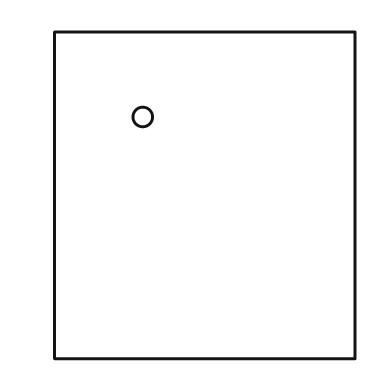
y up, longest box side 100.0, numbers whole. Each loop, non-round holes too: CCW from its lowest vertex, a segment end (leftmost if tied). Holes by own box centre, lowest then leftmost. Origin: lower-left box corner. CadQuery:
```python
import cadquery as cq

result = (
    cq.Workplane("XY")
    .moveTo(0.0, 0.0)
    .lineTo(92.0, 0.0)
    .lineTo(92.0, 100.0)
    .lineTo(0.0, 100.0)
    .close()
    .moveTo(27.0, 74.0)
    .circle(3.0)
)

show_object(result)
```